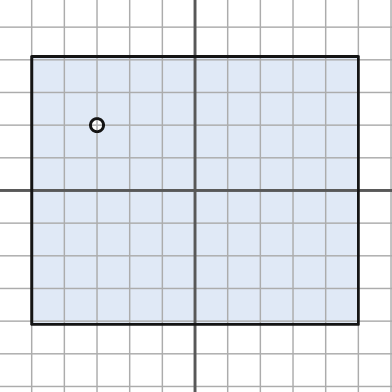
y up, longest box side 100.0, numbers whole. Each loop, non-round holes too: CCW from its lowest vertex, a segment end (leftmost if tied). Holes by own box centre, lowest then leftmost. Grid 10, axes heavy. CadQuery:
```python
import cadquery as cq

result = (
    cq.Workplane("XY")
    .moveTo(-50.0, -41.0)
    .lineTo(50.0, -41.0)
    .lineTo(50.0, 41.0)
    .lineTo(-50.0, 41.0)
    .close()
    .moveTo(-30.0, 20.0)
    .circle(2.0)
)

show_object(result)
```